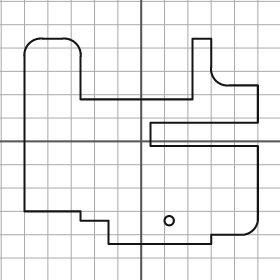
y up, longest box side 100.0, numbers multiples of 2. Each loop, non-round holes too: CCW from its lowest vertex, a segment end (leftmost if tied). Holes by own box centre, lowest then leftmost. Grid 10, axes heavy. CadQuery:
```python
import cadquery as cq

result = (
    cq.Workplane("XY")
    .moveTo(-14.0, -44.0)
    .lineTo(30.0, -44.0)
    .lineTo(30.0, -40.0)
    .lineTo(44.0, -40.0)
    .threePointArc((48.0, -38.0), (50.0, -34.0))
    .lineTo(50.0, -2.0)
    .lineTo(4.0, -2.0)
    .lineTo(4.0, 8.0)
    .lineTo(50.0, 8.0)
    .lineTo(50.0, 24.0)
    .lineTo(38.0, 24.0)
    .threePointArc((32.0, 26.0), (30.0, 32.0))
    .lineTo(30.0, 44.0)
    .lineTo(22.0, 44.0)
    .lineTo(22.0, 18.0)
    .lineTo(-26.0, 18.0)
    .lineTo(-26.0, 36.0)
    .threePointArc((-28.0, 42.0), (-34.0, 44.0))
    .lineTo(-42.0, 44.0)
    .threePointArc((-48.0, 42.0), (-50.0, 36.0))
    .lineTo(-50.0, -30.0)
    .lineTo(-26.0, -30.0)
    .lineTo(-26.0, -34.0)
    .lineTo(-14.0, -34.0)
    .close()
    .moveTo(12.0, -34.0)
    .circle(2.0)
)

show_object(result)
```